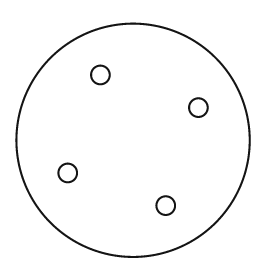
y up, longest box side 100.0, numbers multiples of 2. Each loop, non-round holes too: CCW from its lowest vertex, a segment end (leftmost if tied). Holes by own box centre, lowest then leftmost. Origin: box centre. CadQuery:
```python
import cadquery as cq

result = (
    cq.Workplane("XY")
    .moveTo(0.0, 0.0)
    .circle(50.0)
    .moveTo(14.0, -28.0)
    .circle(4.0)
    .moveTo(-28.0, -14.0)
    .circle(4.0)
    .moveTo(28.0, 14.0)
    .circle(4.0)
    .moveTo(-14.0, 28.0)
    .circle(4.0)
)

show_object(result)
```